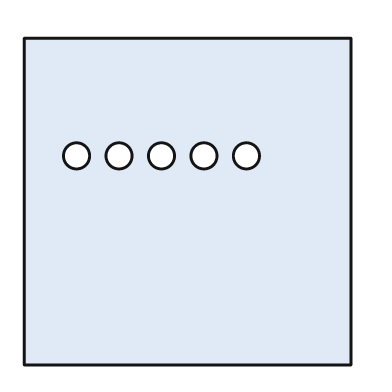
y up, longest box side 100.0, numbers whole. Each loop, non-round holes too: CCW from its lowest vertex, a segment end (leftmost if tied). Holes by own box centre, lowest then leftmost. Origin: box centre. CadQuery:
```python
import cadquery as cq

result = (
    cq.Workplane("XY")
    .moveTo(-50.0, -50.0)
    .lineTo(50.0, -50.0)
    .lineTo(50.0, 50.0)
    .lineTo(-50.0, 50.0)
    .close()
    .moveTo(-34.0, 14.0)
    .circle(4.0)
    .moveTo(-21.0, 14.0)
    .circle(4.0)
    .moveTo(-8.0, 14.0)
    .circle(4.0)
    .moveTo(5.0, 14.0)
    .circle(4.0)
    .moveTo(18.0, 14.0)
    .circle(4.0)
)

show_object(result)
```